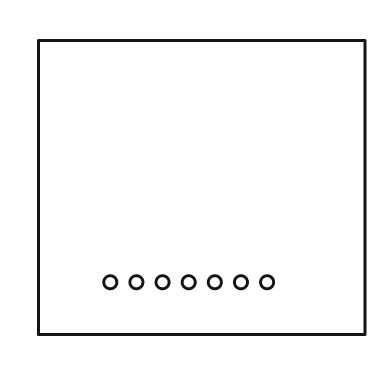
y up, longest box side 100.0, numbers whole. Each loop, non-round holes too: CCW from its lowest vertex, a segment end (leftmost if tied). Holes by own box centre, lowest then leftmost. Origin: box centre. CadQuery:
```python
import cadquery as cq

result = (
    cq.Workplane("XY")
    .moveTo(-50.0, -45.0)
    .lineTo(50.0, -45.0)
    .lineTo(50.0, 45.0)
    .lineTo(-50.0, 45.0)
    .close()
    .moveTo(-28.0, -29.0)
    .circle(2.0)
    .moveTo(-20.0, -29.0)
    .circle(2.0)
    .moveTo(-12.0, -29.0)
    .circle(2.0)
    .moveTo(-4.0, -29.0)
    .circle(2.0)
    .moveTo(4.0, -29.0)
    .circle(2.0)
    .moveTo(12.0, -29.0)
    .circle(2.0)
    .moveTo(20.0, -29.0)
    .circle(2.0)
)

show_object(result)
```